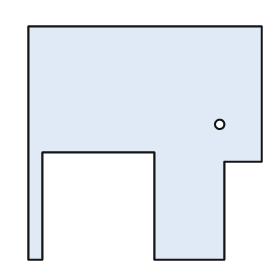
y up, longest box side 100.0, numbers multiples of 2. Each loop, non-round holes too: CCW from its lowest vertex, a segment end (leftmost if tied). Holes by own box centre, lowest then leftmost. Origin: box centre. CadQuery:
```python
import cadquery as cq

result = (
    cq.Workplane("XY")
    .moveTo(-50.0, -50.0)
    .lineTo(-44.0, -50.0)
    .lineTo(-44.0, -4.0)
    .lineTo(4.0, -4.0)
    .lineTo(4.0, -50.0)
    .lineTo(34.0, -50.0)
    .lineTo(34.0, -8.0)
    .lineTo(50.0, -8.0)
    .lineTo(50.0, 50.0)
    .lineTo(-50.0, 50.0)
    .close()
    .moveTo(32.0, 8.0)
    .circle(2.0)
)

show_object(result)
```